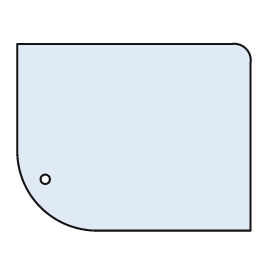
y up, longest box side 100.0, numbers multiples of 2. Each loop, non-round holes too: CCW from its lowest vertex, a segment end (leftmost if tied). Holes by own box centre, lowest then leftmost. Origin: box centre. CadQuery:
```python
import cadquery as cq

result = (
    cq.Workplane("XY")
    .moveTo(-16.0, -40.0)
    .lineTo(50.0, -40.0)
    .lineTo(50.0, 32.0)
    .threePointArc((48.0, 38.0), (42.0, 40.0))
    .lineTo(-50.0, 40.0)
    .lineTo(-50.0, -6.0)
    .threePointArc((-40.0, -30.0), (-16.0, -40.0))
    .close()
    .moveTo(-38.0, -18.0)
    .circle(2.0)
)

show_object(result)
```